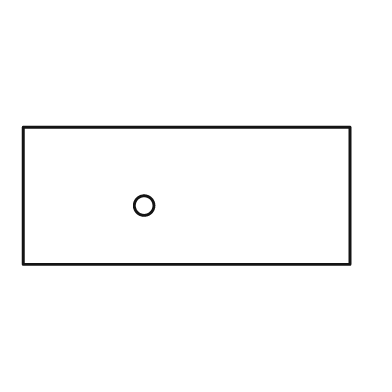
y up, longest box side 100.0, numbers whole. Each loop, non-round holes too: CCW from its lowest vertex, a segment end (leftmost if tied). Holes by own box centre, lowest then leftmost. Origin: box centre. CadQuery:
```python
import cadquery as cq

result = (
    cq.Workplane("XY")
    .moveTo(-50.0, -21.0)
    .lineTo(50.0, -21.0)
    .lineTo(50.0, 21.0)
    .lineTo(-50.0, 21.0)
    .close()
    .moveTo(-13.0, -3.0)
    .circle(3.0)
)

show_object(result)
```